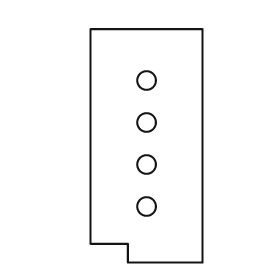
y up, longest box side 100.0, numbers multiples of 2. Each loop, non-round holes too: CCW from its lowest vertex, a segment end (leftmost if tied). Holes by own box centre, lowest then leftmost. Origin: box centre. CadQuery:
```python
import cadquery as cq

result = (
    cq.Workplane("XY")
    .moveTo(-8.0, -50.0)
    .lineTo(24.0, -50.0)
    .lineTo(24.0, 50.0)
    .lineTo(-24.0, 50.0)
    .lineTo(-24.0, -42.0)
    .lineTo(-8.0, -42.0)
    .close()
    .moveTo(0.0, -26.0)
    .circle(4.0)
    .moveTo(0.0, -8.0)
    .circle(4.0)
    .moveTo(0.0, 10.0)
    .circle(4.0)
    .moveTo(0.0, 28.0)
    .circle(4.0)
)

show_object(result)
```